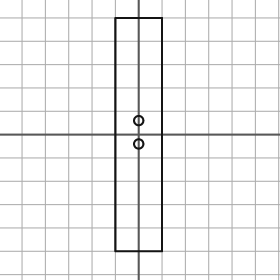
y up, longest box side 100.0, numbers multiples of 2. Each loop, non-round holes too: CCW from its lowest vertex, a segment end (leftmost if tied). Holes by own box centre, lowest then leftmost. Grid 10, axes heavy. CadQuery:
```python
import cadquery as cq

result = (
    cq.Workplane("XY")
    .moveTo(-10.0, -50.0)
    .lineTo(10.0, -50.0)
    .lineTo(10.0, 50.0)
    .lineTo(-10.0, 50.0)
    .close()
    .moveTo(0.0, -4.0)
    .circle(2.0)
    .moveTo(0.0, 6.0)
    .circle(2.0)
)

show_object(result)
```